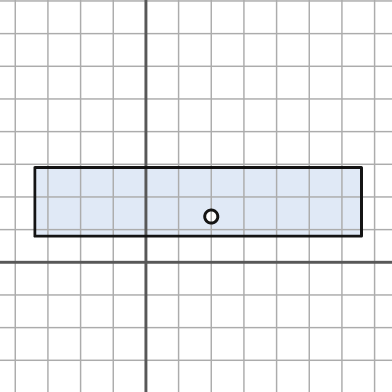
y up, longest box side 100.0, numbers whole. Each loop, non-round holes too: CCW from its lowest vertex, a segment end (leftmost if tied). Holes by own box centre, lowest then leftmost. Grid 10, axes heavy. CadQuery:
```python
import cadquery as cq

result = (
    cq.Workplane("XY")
    .moveTo(-34.0, 8.0)
    .lineTo(66.0, 8.0)
    .lineTo(66.0, 29.0)
    .lineTo(-34.0, 29.0)
    .close()
    .moveTo(20.0, 14.0)
    .circle(2.0)
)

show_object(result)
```